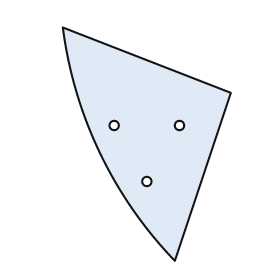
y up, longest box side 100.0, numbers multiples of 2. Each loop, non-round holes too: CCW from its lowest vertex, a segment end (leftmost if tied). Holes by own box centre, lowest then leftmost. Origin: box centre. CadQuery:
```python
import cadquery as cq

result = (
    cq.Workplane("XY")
    .moveTo(12.0, -50.0)
    .lineTo(36.0, 22.0)
    .lineTo(-36.0, 50.0)
    .threePointArc((-20.0, -4.0), (12.0, -50.0))
    .close()
    .moveTo(0.0, -16.0)
    .circle(2.0)
    .moveTo(-14.0, 8.0)
    .circle(2.0)
    .moveTo(14.0, 8.0)
    .circle(2.0)
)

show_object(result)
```